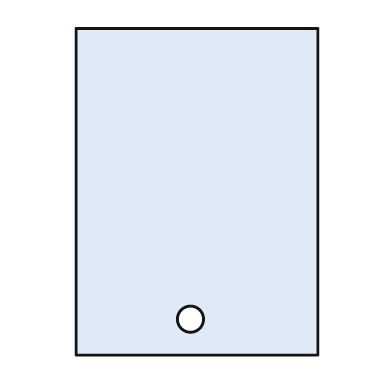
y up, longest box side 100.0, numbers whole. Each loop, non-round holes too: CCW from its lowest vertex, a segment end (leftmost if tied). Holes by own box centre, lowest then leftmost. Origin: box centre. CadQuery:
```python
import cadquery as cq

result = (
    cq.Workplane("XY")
    .moveTo(-37.0, -50.0)
    .lineTo(37.0, -50.0)
    .lineTo(37.0, 50.0)
    .lineTo(-37.0, 50.0)
    .close()
    .moveTo(-2.0, -39.0)
    .circle(4.0)
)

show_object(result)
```